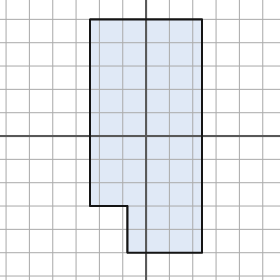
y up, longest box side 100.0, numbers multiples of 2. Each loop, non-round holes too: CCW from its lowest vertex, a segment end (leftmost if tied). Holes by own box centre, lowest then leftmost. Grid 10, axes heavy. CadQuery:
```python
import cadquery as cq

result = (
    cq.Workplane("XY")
    .moveTo(-8.0, -50.0)
    .lineTo(24.0, -50.0)
    .lineTo(24.0, 50.0)
    .lineTo(-24.0, 50.0)
    .lineTo(-24.0, -30.0)
    .lineTo(-8.0, -30.0)
    .close()
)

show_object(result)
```